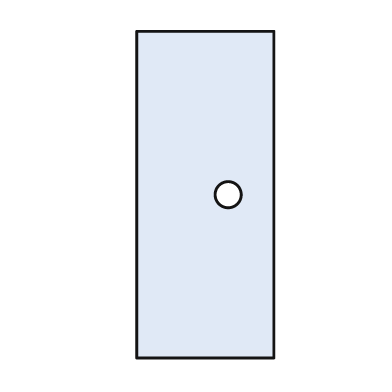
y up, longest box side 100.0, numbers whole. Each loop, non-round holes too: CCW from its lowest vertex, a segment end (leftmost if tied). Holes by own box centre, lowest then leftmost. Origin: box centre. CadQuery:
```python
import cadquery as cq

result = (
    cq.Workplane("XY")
    .moveTo(-21.0, -50.0)
    .lineTo(21.0, -50.0)
    .lineTo(21.0, 50.0)
    .lineTo(-21.0, 50.0)
    .close()
    .moveTo(7.0, 0.0)
    .circle(4.0)
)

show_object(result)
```